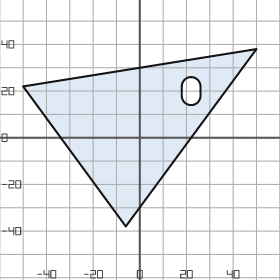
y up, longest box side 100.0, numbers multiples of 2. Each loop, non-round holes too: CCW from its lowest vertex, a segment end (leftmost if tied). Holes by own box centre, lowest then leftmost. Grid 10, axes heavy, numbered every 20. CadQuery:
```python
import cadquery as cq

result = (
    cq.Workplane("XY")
    .moveTo(-6.0, -38.0)
    .lineTo(50.0, 38.0)
    .lineTo(-50.0, 22.0)
    .close()
    .moveTo(18.0, 18.0)
    .threePointArc((22.0, 14.0), (26.0, 18.0))
    .lineTo(26.0, 22.0)
    .threePointArc((22.0, 26.0), (18.0, 22.0))
    .close()
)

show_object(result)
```